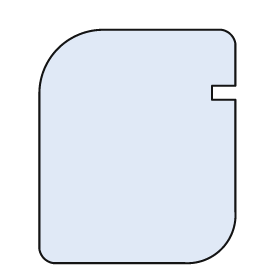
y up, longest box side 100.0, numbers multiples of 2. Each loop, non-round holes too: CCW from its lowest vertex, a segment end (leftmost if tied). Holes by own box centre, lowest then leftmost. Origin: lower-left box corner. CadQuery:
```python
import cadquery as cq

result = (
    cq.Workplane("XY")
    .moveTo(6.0, 0.0)
    .lineTo(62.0, 0.0)
    .threePointArc((78.0, 6.0), (84.0, 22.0))
    .lineTo(84.0, 70.0)
    .lineTo(74.0, 70.0)
    .lineTo(74.0, 76.0)
    .lineTo(84.0, 76.0)
    .lineTo(84.0, 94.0)
    .threePointArc((82.0, 98.0), (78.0, 100.0))
    .lineTo(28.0, 100.0)
    .threePointArc((8.0, 92.0), (0.0, 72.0))
    .lineTo(0.0, 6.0)
    .threePointArc((2.0, 2.0), (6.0, 0.0))
    .close()
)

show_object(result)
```